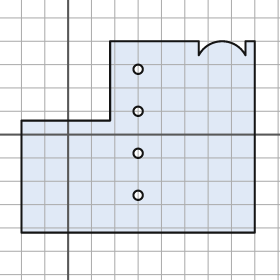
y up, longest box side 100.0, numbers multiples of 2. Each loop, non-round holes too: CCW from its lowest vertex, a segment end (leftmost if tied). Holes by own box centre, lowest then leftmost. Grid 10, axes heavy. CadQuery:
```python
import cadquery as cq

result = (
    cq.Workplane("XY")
    .moveTo(-20.0, -42.0)
    .lineTo(80.0, -42.0)
    .lineTo(80.0, 40.0)
    .lineTo(76.0, 40.0)
    .lineTo(76.0, 34.0)
    .threePointArc((66.0, 40.0), (56.0, 34.0))
    .lineTo(56.0, 40.0)
    .lineTo(18.0, 40.0)
    .lineTo(18.0, 6.0)
    .lineTo(-20.0, 6.0)
    .close()
    .moveTo(30.0, -26.0)
    .circle(2.0)
    .moveTo(30.0, -8.0)
    .circle(2.0)
    .moveTo(30.0, 10.0)
    .circle(2.0)
    .moveTo(30.0, 28.0)
    .circle(2.0)
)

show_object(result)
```